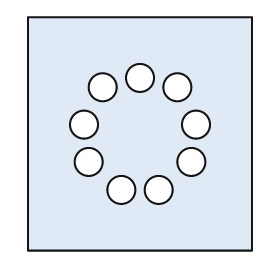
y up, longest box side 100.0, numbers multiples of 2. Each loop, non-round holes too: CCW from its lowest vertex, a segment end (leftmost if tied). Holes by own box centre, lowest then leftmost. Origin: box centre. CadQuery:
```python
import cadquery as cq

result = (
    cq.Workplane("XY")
    .moveTo(-48.0, -50.0)
    .lineTo(48.0, -50.0)
    .lineTo(48.0, 50.0)
    .lineTo(-48.0, 50.0)
    .close()
    .moveTo(-8.0, -24.0)
    .circle(6.0)
    .moveTo(8.0, -24.0)
    .circle(6.0)
    .moveTo(-22.0, -12.0)
    .circle(6.0)
    .moveTo(22.0, -12.0)
    .circle(6.0)
    .moveTo(-24.0, 4.0)
    .circle(6.0)
    .moveTo(24.0, 4.0)
    .circle(6.0)
    .moveTo(-16.0, 20.0)
    .circle(6.0)
    .moveTo(16.0, 20.0)
    .circle(6.0)
    .moveTo(0.0, 24.0)
    .circle(6.0)
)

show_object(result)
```